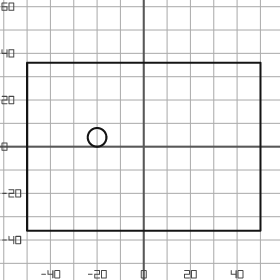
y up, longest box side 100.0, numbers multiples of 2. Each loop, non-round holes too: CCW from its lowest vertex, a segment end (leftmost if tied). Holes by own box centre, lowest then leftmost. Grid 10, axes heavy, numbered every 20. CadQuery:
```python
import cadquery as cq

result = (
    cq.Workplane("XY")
    .moveTo(-50.0, -36.0)
    .lineTo(50.0, -36.0)
    .lineTo(50.0, 36.0)
    .lineTo(-50.0, 36.0)
    .close()
    .moveTo(-20.0, 4.0)
    .circle(4.0)
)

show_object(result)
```